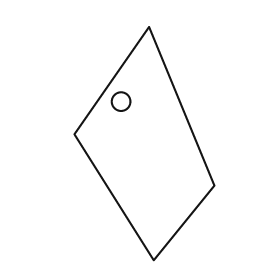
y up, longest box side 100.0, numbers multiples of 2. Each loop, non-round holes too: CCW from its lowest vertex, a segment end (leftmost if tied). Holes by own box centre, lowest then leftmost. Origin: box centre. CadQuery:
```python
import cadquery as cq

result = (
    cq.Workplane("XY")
    .moveTo(4.0, -50.0)
    .lineTo(30.0, -18.0)
    .lineTo(2.0, 50.0)
    .lineTo(-30.0, 4.0)
    .close()
    .moveTo(-10.0, 18.0)
    .circle(4.0)
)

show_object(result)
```